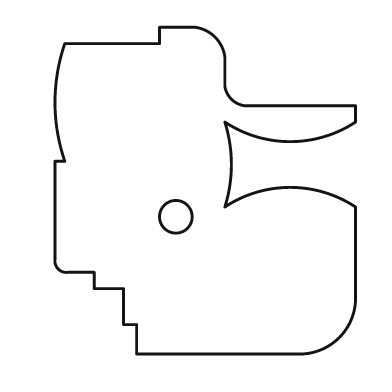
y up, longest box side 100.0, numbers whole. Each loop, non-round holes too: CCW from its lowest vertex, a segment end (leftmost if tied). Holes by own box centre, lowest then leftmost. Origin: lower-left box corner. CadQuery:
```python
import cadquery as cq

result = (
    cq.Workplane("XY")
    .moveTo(25.0, 0.0)
    .lineTo(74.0, 0.0)
    .threePointArc((87.0, 5.0), (92.0, 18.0))
    .lineTo(92.0, 45.0)
    .threePointArc((72.0, 51.0), (52.0, 45.0))
    .threePointArc((54.0, 58.0), (52.0, 71.0))
    .threePointArc((72.0, 65.0), (92.0, 71.0))
    .lineTo(92.0, 76.0)
    .lineTo(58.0, 76.0)
    .threePointArc((54.0, 78.0), (52.0, 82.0))
    .lineTo(52.0, 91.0)
    .threePointArc((49.0, 97.0), (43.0, 100.0))
    .lineTo(32.0, 100.0)
    .lineTo(32.0, 95.0)
    .lineTo(3.0, 95.0)
    .threePointArc((0.0, 77.0), (3.0, 59.0))
    .lineTo(0.0, 59.0)
    .lineTo(0.0, 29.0)
    .threePointArc((1.0, 26.0), (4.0, 25.0))
    .lineTo(12.0, 25.0)
    .lineTo(12.0, 20.0)
    .lineTo(21.0, 20.0)
    .lineTo(21.0, 9.0)
    .lineTo(25.0, 9.0)
    .close()
    .moveTo(37.0, 42.0)
    .circle(5.0)
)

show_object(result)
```